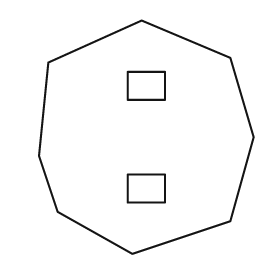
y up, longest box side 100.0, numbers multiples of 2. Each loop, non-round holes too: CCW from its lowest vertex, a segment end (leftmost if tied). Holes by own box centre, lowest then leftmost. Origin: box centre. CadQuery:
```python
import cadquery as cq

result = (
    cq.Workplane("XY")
    .moveTo(-6.0, -50.0)
    .lineTo(36.0, -36.0)
    .lineTo(46.0, 0.0)
    .lineTo(36.0, 34.0)
    .lineTo(-2.0, 50.0)
    .lineTo(-42.0, 32.0)
    .lineTo(-46.0, -8.0)
    .lineTo(-38.0, -32.0)
    .close()
    .moveTo(-8.0, -28.0)
    .lineTo(8.0, -28.0)
    .lineTo(8.0, -16.0)
    .lineTo(-8.0, -16.0)
    .close()
    .moveTo(-8.0, 16.0)
    .lineTo(8.0, 16.0)
    .lineTo(8.0, 28.0)
    .lineTo(-8.0, 28.0)
    .close()
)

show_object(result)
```